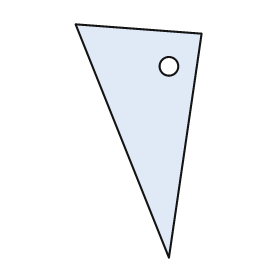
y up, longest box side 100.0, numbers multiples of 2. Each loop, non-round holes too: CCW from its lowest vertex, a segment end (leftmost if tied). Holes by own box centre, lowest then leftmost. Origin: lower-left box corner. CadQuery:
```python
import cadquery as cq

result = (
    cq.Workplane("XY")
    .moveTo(40.0, 0.0)
    .lineTo(54.0, 96.0)
    .lineTo(0.0, 100.0)
    .close()
    .moveTo(40.0, 82.0)
    .circle(4.0)
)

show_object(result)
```